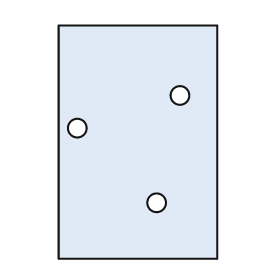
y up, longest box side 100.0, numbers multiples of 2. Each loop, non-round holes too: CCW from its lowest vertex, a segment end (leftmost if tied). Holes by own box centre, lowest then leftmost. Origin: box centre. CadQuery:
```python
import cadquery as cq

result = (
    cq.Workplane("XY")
    .moveTo(-34.0, -50.0)
    .lineTo(34.0, -50.0)
    .lineTo(34.0, 50.0)
    .lineTo(-34.0, 50.0)
    .close()
    .moveTo(8.0, -26.0)
    .circle(4.0)
    .moveTo(-26.0, 6.0)
    .circle(4.0)
    .moveTo(18.0, 20.0)
    .circle(4.0)
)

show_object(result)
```